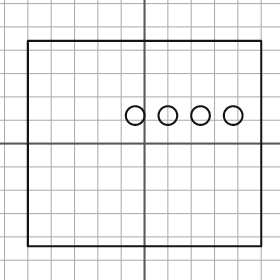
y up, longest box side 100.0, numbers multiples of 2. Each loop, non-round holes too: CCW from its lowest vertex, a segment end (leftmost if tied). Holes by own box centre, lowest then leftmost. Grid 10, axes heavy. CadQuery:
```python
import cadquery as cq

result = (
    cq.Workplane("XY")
    .moveTo(-50.0, -44.0)
    .lineTo(50.0, -44.0)
    .lineTo(50.0, 44.0)
    .lineTo(-50.0, 44.0)
    .close()
    .moveTo(-4.0, 12.0)
    .circle(4.0)
    .moveTo(10.0, 12.0)
    .circle(4.0)
    .moveTo(24.0, 12.0)
    .circle(4.0)
    .moveTo(38.0, 12.0)
    .circle(4.0)
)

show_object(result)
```